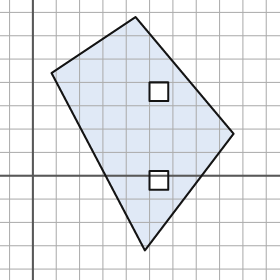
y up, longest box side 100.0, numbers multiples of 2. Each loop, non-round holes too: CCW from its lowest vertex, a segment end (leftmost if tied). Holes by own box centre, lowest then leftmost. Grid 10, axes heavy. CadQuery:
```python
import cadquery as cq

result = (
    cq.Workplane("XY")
    .moveTo(48.0, -32.0)
    .lineTo(86.0, 18.0)
    .lineTo(44.0, 68.0)
    .lineTo(8.0, 44.0)
    .close()
    .moveTo(50.0, -6.0)
    .lineTo(58.0, -6.0)
    .lineTo(58.0, 2.0)
    .lineTo(50.0, 2.0)
    .close()
    .moveTo(50.0, 32.0)
    .lineTo(58.0, 32.0)
    .lineTo(58.0, 40.0)
    .lineTo(50.0, 40.0)
    .close()
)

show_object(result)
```